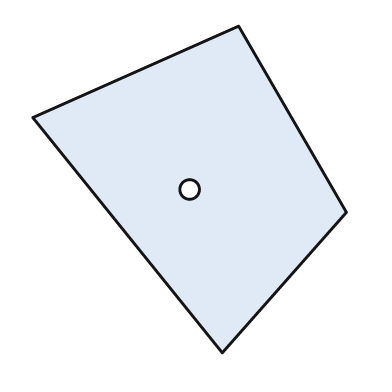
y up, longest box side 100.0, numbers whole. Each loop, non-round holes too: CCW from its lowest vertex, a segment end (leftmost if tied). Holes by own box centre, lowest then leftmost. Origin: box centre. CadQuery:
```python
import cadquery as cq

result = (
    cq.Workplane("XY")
    .moveTo(10.0, -50.0)
    .lineTo(48.0, -7.0)
    .lineTo(15.0, 50.0)
    .lineTo(-48.0, 22.0)
    .close()
    .moveTo(0.0, 0.0)
    .circle(3.0)
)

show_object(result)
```